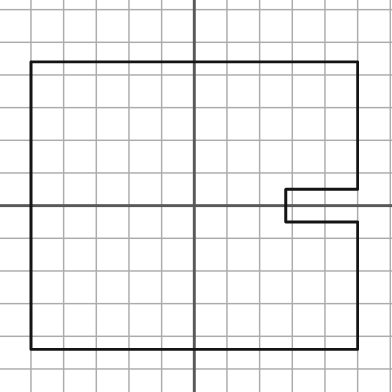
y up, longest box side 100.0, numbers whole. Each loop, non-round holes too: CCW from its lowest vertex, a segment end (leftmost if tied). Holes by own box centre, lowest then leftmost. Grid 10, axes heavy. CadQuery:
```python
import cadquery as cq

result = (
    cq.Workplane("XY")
    .moveTo(-50.0, -44.0)
    .lineTo(50.0, -44.0)
    .lineTo(50.0, -5.0)
    .lineTo(28.0, -5.0)
    .lineTo(28.0, 5.0)
    .lineTo(50.0, 5.0)
    .lineTo(50.0, 44.0)
    .lineTo(-50.0, 44.0)
    .close()
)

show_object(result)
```